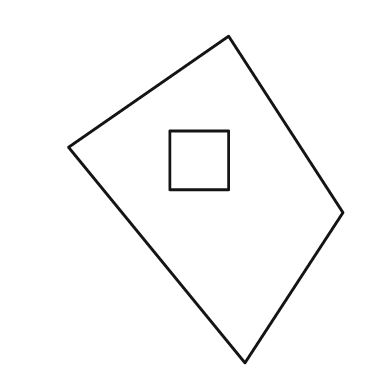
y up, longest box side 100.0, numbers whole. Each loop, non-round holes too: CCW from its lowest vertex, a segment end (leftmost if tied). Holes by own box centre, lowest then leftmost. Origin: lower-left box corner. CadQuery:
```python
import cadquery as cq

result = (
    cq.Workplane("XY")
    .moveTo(54.0, 0.0)
    .lineTo(84.0, 46.0)
    .lineTo(49.0, 100.0)
    .lineTo(0.0, 66.0)
    .close()
    .moveTo(31.0, 53.0)
    .lineTo(49.0, 53.0)
    .lineTo(49.0, 71.0)
    .lineTo(31.0, 71.0)
    .close()
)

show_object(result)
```